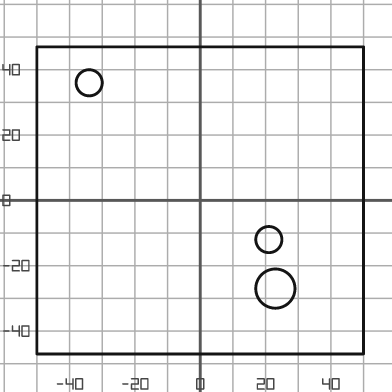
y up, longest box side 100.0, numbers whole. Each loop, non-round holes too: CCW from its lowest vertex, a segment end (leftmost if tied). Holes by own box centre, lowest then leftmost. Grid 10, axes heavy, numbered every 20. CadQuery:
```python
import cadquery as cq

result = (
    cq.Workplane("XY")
    .moveTo(-50.0, -47.0)
    .lineTo(50.0, -47.0)
    .lineTo(50.0, 47.0)
    .lineTo(-50.0, 47.0)
    .close()
    .moveTo(23.0, -27.0)
    .circle(6.0)
    .moveTo(21.0, -12.0)
    .circle(4.0)
    .moveTo(-34.0, 36.0)
    .circle(4.0)
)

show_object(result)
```